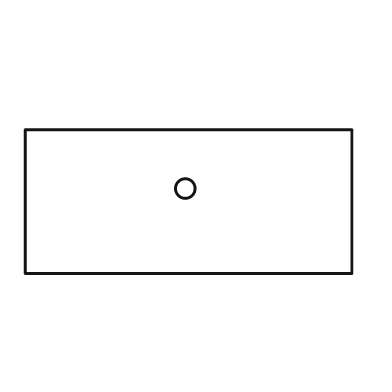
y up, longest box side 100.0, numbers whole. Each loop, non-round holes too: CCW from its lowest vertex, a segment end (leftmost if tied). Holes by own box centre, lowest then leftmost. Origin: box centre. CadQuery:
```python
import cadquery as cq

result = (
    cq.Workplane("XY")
    .moveTo(-50.0, -22.0)
    .lineTo(50.0, -22.0)
    .lineTo(50.0, 22.0)
    .lineTo(-50.0, 22.0)
    .close()
    .moveTo(-1.0, 4.0)
    .circle(3.0)
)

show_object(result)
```